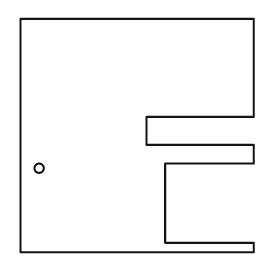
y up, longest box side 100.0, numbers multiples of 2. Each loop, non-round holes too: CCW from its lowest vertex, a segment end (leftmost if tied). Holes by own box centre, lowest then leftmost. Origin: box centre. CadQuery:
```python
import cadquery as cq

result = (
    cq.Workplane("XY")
    .moveTo(-50.0, -50.0)
    .lineTo(50.0, -50.0)
    .lineTo(50.0, -46.0)
    .lineTo(12.0, -46.0)
    .lineTo(12.0, -12.0)
    .lineTo(50.0, -12.0)
    .lineTo(50.0, -4.0)
    .lineTo(4.0, -4.0)
    .lineTo(4.0, 8.0)
    .lineTo(50.0, 8.0)
    .lineTo(50.0, 50.0)
    .lineTo(-50.0, 50.0)
    .close()
    .moveTo(-42.0, -14.0)
    .circle(2.0)
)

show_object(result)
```